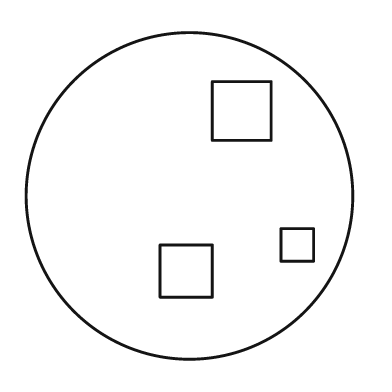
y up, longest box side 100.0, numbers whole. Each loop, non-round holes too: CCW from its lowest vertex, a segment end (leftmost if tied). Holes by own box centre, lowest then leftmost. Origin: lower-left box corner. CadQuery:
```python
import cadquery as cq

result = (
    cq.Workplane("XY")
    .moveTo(50.0, 50.0)
    .circle(50.0)
    .moveTo(41.0, 19.0)
    .lineTo(57.0, 19.0)
    .lineTo(57.0, 35.0)
    .lineTo(41.0, 35.0)
    .close()
    .moveTo(78.0, 30.0)
    .lineTo(88.0, 30.0)
    .lineTo(88.0, 40.0)
    .lineTo(78.0, 40.0)
    .close()
    .moveTo(57.0, 67.0)
    .lineTo(75.0, 67.0)
    .lineTo(75.0, 85.0)
    .lineTo(57.0, 85.0)
    .close()
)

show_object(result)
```